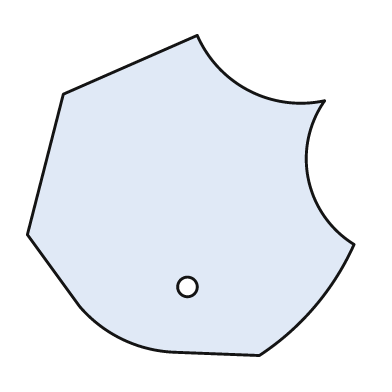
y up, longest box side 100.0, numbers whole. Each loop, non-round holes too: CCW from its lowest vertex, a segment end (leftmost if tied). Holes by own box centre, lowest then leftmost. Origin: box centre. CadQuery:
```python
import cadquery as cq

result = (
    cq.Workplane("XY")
    .moveTo(21.0, -49.0)
    .threePointArc((38.0, -34.0), (50.0, -15.0))
    .threePointArc((36.0, 5.0), (41.0, 29.0))
    .threePointArc((18.0, 32.0), (2.0, 49.0))
    .lineTo(-39.0, 31.0)
    .lineTo(-50.0, -12.0)
    .lineTo(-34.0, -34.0)
    .threePointArc((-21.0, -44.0), (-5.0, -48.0))
    .close()
    .moveTo(-1.0, -28.0)
    .circle(3.0)
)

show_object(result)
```